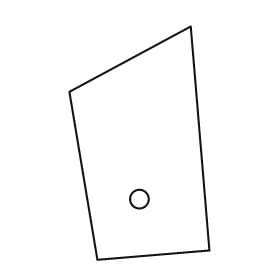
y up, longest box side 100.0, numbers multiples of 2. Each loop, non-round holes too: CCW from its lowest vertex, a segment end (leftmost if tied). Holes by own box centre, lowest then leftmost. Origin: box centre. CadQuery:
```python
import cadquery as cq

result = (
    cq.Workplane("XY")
    .moveTo(-18.0, -50.0)
    .lineTo(30.0, -46.0)
    .lineTo(22.0, 50.0)
    .lineTo(-30.0, 22.0)
    .close()
    .moveTo(0.0, -24.0)
    .circle(4.0)
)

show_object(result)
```